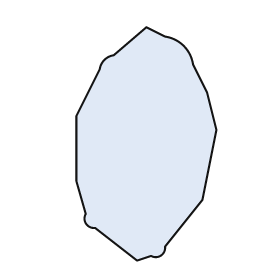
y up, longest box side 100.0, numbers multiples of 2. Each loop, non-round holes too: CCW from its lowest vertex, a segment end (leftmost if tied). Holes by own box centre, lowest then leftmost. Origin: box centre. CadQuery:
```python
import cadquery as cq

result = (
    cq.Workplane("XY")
    .moveTo(-4.0, -50.0)
    .lineTo(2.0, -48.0)
    .threePointArc((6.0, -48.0), (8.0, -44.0))
    .lineTo(24.0, -24.0)
    .lineTo(30.0, 6.0)
    .lineTo(26.0, 22.0)
    .lineTo(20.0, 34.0)
    .threePointArc((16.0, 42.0), (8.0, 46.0))
    .lineTo(0.0, 50.0)
    .lineTo(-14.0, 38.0)
    .threePointArc((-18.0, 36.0), (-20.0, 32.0))
    .lineTo(-30.0, 12.0)
    .lineTo(-30.0, -16.0)
    .lineTo(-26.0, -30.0)
    .threePointArc((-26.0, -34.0), (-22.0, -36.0))
    .close()
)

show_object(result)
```